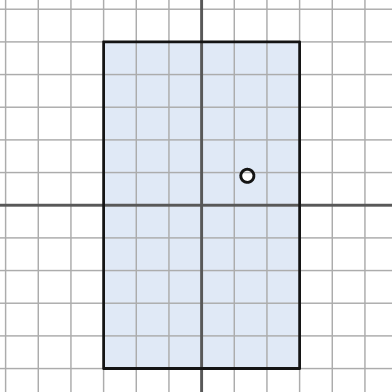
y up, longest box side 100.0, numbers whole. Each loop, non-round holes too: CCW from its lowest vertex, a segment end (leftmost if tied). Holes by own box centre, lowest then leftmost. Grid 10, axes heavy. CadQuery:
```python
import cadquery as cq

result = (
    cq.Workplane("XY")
    .moveTo(-30.0, -50.0)
    .lineTo(30.0, -50.0)
    .lineTo(30.0, 50.0)
    .lineTo(-30.0, 50.0)
    .close()
    .moveTo(14.0, 9.0)
    .circle(2.0)
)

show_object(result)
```